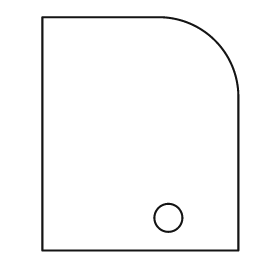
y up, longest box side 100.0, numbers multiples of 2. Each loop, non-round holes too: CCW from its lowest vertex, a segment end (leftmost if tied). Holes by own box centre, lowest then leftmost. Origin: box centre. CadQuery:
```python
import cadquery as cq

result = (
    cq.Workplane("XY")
    .moveTo(-42.0, -50.0)
    .lineTo(42.0, -50.0)
    .lineTo(42.0, 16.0)
    .threePointArc((32.0, 40.0), (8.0, 50.0))
    .lineTo(-42.0, 50.0)
    .close()
    .moveTo(12.0, -36.0)
    .circle(6.0)
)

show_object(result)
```